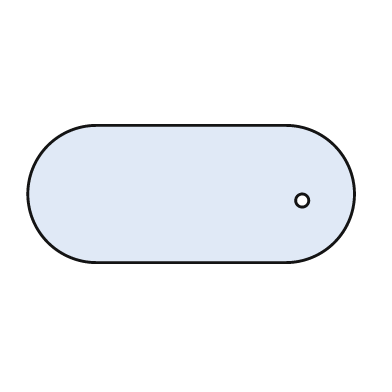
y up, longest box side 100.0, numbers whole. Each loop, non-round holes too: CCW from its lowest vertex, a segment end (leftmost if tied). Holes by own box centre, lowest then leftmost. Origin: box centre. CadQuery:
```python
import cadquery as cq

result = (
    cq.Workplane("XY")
    .moveTo(-29.0, -21.0)
    .lineTo(29.0, -21.0)
    .threePointArc((50.0, 0.0), (29.0, 21.0))
    .lineTo(-29.0, 21.0)
    .threePointArc((-50.0, 0.0), (-29.0, -21.0))
    .close()
    .moveTo(34.0, -2.0)
    .circle(2.0)
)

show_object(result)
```